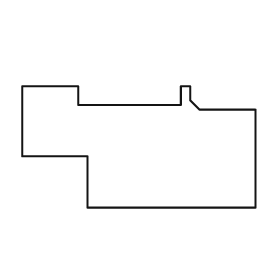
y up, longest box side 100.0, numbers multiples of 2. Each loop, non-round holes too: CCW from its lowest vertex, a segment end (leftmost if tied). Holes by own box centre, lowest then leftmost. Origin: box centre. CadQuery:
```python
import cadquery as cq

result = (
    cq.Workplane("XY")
    .moveTo(-22.0, -26.0)
    .lineTo(50.0, -26.0)
    .lineTo(50.0, 16.0)
    .lineTo(26.0, 16.0)
    .lineTo(22.0, 20.0)
    .lineTo(22.0, 26.0)
    .lineTo(18.0, 26.0)
    .lineTo(18.0, 18.0)
    .lineTo(-26.0, 18.0)
    .lineTo(-26.0, 26.0)
    .lineTo(-50.0, 26.0)
    .lineTo(-50.0, -4.0)
    .lineTo(-22.0, -4.0)
    .close()
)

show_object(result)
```